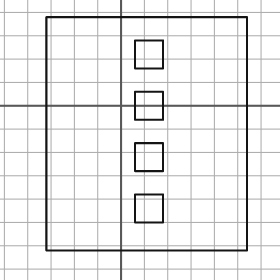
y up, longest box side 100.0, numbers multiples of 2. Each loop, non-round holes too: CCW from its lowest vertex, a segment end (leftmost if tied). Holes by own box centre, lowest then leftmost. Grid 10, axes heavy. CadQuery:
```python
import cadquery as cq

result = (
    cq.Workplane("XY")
    .moveTo(-32.0, -62.0)
    .lineTo(54.0, -62.0)
    .lineTo(54.0, 38.0)
    .lineTo(-32.0, 38.0)
    .close()
    .moveTo(6.0, -50.0)
    .lineTo(18.0, -50.0)
    .lineTo(18.0, -38.0)
    .lineTo(6.0, -38.0)
    .close()
    .moveTo(6.0, -28.0)
    .lineTo(18.0, -28.0)
    .lineTo(18.0, -16.0)
    .lineTo(6.0, -16.0)
    .close()
    .moveTo(6.0, -6.0)
    .lineTo(18.0, -6.0)
    .lineTo(18.0, 6.0)
    .lineTo(6.0, 6.0)
    .close()
    .moveTo(6.0, 16.0)
    .lineTo(18.0, 16.0)
    .lineTo(18.0, 28.0)
    .lineTo(6.0, 28.0)
    .close()
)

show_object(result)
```